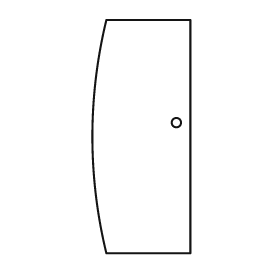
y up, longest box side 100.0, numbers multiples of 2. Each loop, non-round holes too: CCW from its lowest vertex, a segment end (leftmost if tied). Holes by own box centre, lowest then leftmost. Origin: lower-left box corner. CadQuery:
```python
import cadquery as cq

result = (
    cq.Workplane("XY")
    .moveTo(6.0, 0.0)
    .lineTo(42.0, 0.0)
    .lineTo(42.0, 100.0)
    .lineTo(6.0, 100.0)
    .threePointArc((0.0, 50.0), (6.0, 0.0))
    .close()
    .moveTo(36.0, 56.0)
    .circle(2.0)
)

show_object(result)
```